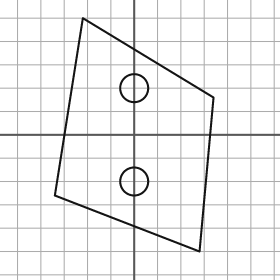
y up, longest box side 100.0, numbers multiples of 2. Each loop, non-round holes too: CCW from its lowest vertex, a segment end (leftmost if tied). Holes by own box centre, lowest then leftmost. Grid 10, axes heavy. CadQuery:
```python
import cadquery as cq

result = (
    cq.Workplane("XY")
    .moveTo(28.0, -50.0)
    .lineTo(34.0, 16.0)
    .lineTo(-22.0, 50.0)
    .lineTo(-34.0, -26.0)
    .close()
    .moveTo(0.0, -20.0)
    .circle(6.0)
    .moveTo(0.0, 20.0)
    .circle(6.0)
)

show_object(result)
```